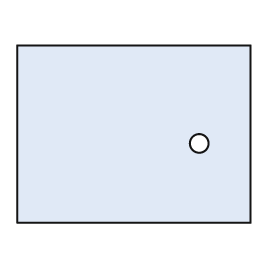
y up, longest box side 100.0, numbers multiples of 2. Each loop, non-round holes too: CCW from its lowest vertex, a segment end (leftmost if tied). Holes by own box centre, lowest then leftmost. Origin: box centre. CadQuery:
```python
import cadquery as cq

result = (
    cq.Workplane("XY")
    .moveTo(-50.0, -38.0)
    .lineTo(50.0, -38.0)
    .lineTo(50.0, 38.0)
    .lineTo(-50.0, 38.0)
    .close()
    .moveTo(28.0, -4.0)
    .circle(4.0)
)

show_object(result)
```